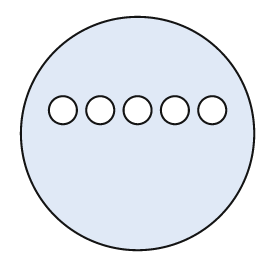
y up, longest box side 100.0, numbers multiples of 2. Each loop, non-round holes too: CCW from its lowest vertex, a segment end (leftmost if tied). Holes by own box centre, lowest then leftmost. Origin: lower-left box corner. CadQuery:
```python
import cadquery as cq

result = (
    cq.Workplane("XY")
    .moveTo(50.0, 50.0)
    .circle(50.0)
    .moveTo(18.0, 60.0)
    .circle(6.0)
    .moveTo(34.0, 60.0)
    .circle(6.0)
    .moveTo(50.0, 60.0)
    .circle(6.0)
    .moveTo(66.0, 60.0)
    .circle(6.0)
    .moveTo(82.0, 60.0)
    .circle(6.0)
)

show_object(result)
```